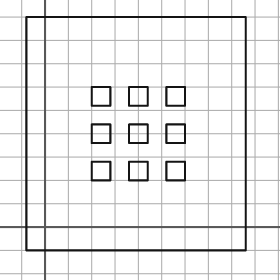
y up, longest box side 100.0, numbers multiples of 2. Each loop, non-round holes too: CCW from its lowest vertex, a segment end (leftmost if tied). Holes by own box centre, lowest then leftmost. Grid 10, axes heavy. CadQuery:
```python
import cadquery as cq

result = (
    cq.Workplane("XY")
    .moveTo(-8.0, -10.0)
    .lineTo(86.0, -10.0)
    .lineTo(86.0, 90.0)
    .lineTo(-8.0, 90.0)
    .close()
    .moveTo(20.0, 20.0)
    .lineTo(28.0, 20.0)
    .lineTo(28.0, 28.0)
    .lineTo(20.0, 28.0)
    .close()
    .moveTo(36.0, 20.0)
    .lineTo(44.0, 20.0)
    .lineTo(44.0, 28.0)
    .lineTo(36.0, 28.0)
    .close()
    .moveTo(52.0, 20.0)
    .lineTo(60.0, 20.0)
    .lineTo(60.0, 28.0)
    .lineTo(52.0, 28.0)
    .close()
    .moveTo(20.0, 36.0)
    .lineTo(28.0, 36.0)
    .lineTo(28.0, 44.0)
    .lineTo(20.0, 44.0)
    .close()
    .moveTo(36.0, 36.0)
    .lineTo(44.0, 36.0)
    .lineTo(44.0, 44.0)
    .lineTo(36.0, 44.0)
    .close()
    .moveTo(52.0, 36.0)
    .lineTo(60.0, 36.0)
    .lineTo(60.0, 44.0)
    .lineTo(52.0, 44.0)
    .close()
    .moveTo(20.0, 52.0)
    .lineTo(28.0, 52.0)
    .lineTo(28.0, 60.0)
    .lineTo(20.0, 60.0)
    .close()
    .moveTo(36.0, 52.0)
    .lineTo(44.0, 52.0)
    .lineTo(44.0, 60.0)
    .lineTo(36.0, 60.0)
    .close()
    .moveTo(52.0, 52.0)
    .lineTo(60.0, 52.0)
    .lineTo(60.0, 60.0)
    .lineTo(52.0, 60.0)
    .close()
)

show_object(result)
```